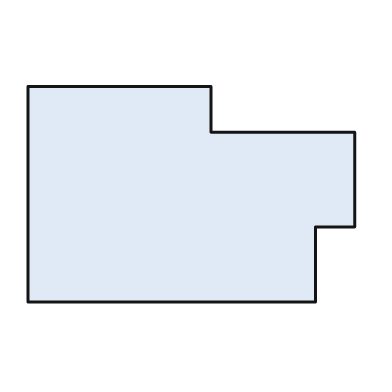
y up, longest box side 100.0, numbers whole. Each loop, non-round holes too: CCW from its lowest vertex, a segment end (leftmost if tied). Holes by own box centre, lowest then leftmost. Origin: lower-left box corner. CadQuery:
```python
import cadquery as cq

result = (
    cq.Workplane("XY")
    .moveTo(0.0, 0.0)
    .lineTo(88.0, 0.0)
    .lineTo(88.0, 23.0)
    .lineTo(100.0, 23.0)
    .lineTo(100.0, 52.0)
    .lineTo(56.0, 52.0)
    .lineTo(56.0, 66.0)
    .lineTo(0.0, 66.0)
    .close()
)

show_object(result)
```